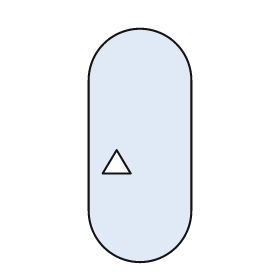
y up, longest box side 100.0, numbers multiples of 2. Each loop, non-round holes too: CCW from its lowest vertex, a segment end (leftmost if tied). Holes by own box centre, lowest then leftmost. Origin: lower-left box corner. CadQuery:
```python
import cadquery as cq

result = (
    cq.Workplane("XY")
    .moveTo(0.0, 22.0)
    .threePointArc((22.0, 0.0), (44.0, 22.0))
    .lineTo(44.0, 78.0)
    .threePointArc((22.0, 100.0), (0.0, 78.0))
    .close()
    .moveTo(6.0, 38.0)
    .lineTo(18.0, 38.0)
    .lineTo(12.0, 48.0)
    .close()
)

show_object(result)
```